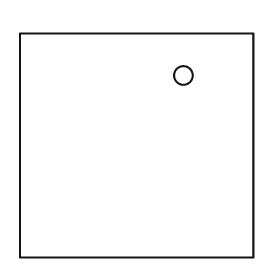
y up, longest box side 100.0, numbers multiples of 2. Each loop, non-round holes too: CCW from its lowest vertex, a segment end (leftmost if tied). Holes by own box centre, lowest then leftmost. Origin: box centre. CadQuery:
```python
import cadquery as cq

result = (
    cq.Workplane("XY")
    .moveTo(-50.0, -48.0)
    .lineTo(50.0, -48.0)
    .lineTo(50.0, 48.0)
    .lineTo(-50.0, 48.0)
    .close()
    .moveTo(20.0, 30.0)
    .circle(4.0)
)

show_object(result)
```